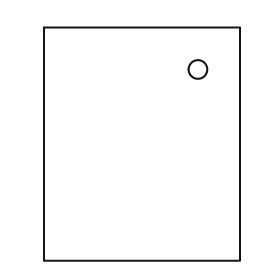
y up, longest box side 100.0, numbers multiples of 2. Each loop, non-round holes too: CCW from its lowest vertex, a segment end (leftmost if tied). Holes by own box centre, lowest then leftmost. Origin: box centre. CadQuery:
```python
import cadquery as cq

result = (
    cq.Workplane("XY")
    .moveTo(-42.0, -50.0)
    .lineTo(42.0, -50.0)
    .lineTo(42.0, 50.0)
    .lineTo(-42.0, 50.0)
    .close()
    .moveTo(24.0, 32.0)
    .circle(4.0)
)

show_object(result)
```